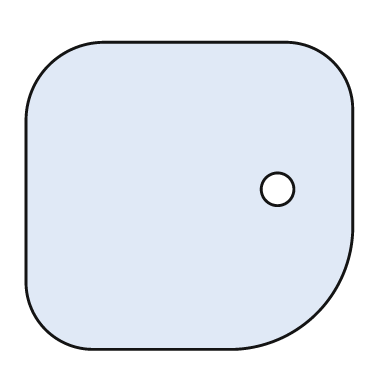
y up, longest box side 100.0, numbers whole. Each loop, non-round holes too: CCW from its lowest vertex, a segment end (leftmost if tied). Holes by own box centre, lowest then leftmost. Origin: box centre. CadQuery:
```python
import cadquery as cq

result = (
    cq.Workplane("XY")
    .moveTo(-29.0, -47.0)
    .lineTo(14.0, -47.0)
    .threePointArc((39.0, -36.0), (50.0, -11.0))
    .lineTo(50.0, 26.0)
    .threePointArc((44.0, 41.0), (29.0, 47.0))
    .lineTo(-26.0, 47.0)
    .threePointArc((-43.0, 40.0), (-50.0, 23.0))
    .lineTo(-50.0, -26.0)
    .threePointArc((-44.0, -41.0), (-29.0, -47.0))
    .close()
    .moveTo(27.0, 2.0)
    .circle(5.0)
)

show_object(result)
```